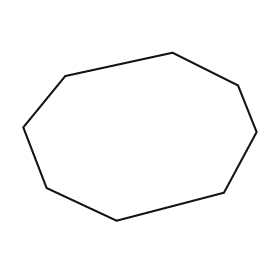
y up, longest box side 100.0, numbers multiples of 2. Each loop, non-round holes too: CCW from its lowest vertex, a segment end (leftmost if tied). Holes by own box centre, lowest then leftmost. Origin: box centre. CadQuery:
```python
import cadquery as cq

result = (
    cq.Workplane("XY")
    .moveTo(-10.0, -36.0)
    .lineTo(36.0, -24.0)
    .lineTo(50.0, 2.0)
    .lineTo(42.0, 22.0)
    .lineTo(14.0, 36.0)
    .lineTo(-32.0, 26.0)
    .lineTo(-50.0, 4.0)
    .lineTo(-40.0, -22.0)
    .close()
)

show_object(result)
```